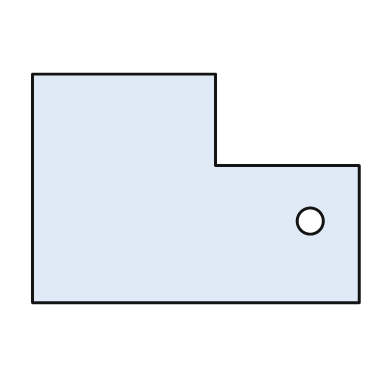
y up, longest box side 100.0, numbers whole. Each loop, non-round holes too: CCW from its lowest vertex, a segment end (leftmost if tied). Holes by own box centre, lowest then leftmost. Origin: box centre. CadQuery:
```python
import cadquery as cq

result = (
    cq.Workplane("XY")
    .moveTo(-50.0, -35.0)
    .lineTo(50.0, -35.0)
    .lineTo(50.0, 7.0)
    .lineTo(6.0, 7.0)
    .lineTo(6.0, 35.0)
    .lineTo(-50.0, 35.0)
    .close()
    .moveTo(35.0, -10.0)
    .circle(4.0)
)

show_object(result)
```